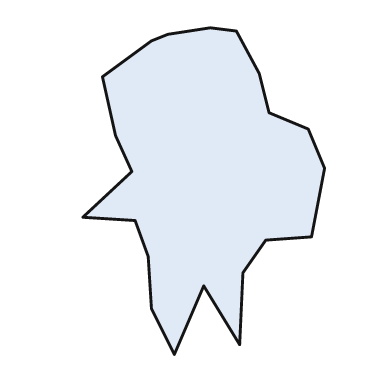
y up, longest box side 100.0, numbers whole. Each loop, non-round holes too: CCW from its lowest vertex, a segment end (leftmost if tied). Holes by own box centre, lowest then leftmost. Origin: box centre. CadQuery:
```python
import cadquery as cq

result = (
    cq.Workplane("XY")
    .moveTo(-9.0, -50.0)
    .lineTo(0.0, -29.0)
    .lineTo(11.0, -47.0)
    .lineTo(12.0, -25.0)
    .lineTo(19.0, -15.0)
    .lineTo(33.0, -14.0)
    .lineTo(37.0, 7.0)
    .lineTo(32.0, 19.0)
    .lineTo(20.0, 24.0)
    .lineTo(17.0, 36.0)
    .lineTo(10.0, 49.0)
    .lineTo(2.0, 50.0)
    .lineTo(-11.0, 48.0)
    .lineTo(-16.0, 46.0)
    .lineTo(-31.0, 35.0)
    .lineTo(-27.0, 17.0)
    .lineTo(-22.0, 6.0)
    .lineTo(-37.0, -8.0)
    .lineTo(-21.0, -9.0)
    .lineTo(-17.0, -20.0)
    .lineTo(-16.0, -36.0)
    .close()
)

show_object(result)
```